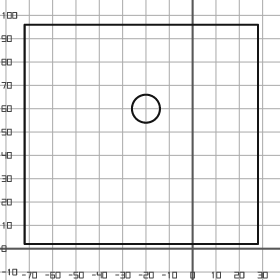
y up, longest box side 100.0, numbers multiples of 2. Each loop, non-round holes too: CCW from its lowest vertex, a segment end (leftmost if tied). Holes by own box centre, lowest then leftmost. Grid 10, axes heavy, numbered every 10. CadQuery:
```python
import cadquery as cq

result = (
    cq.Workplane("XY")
    .moveTo(-72.0, 2.0)
    .lineTo(28.0, 2.0)
    .lineTo(28.0, 96.0)
    .lineTo(-72.0, 96.0)
    .close()
    .moveTo(-20.0, 60.0)
    .circle(6.0)
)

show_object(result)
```